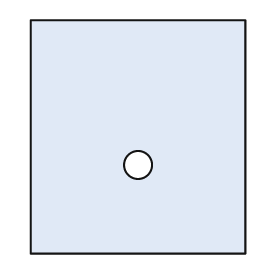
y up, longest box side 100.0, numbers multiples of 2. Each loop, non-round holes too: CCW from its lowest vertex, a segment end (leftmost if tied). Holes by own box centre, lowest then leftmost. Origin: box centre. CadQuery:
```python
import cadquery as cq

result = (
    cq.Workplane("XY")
    .moveTo(-46.0, -50.0)
    .lineTo(46.0, -50.0)
    .lineTo(46.0, 50.0)
    .lineTo(-46.0, 50.0)
    .close()
    .moveTo(0.0, -12.0)
    .circle(6.0)
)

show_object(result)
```